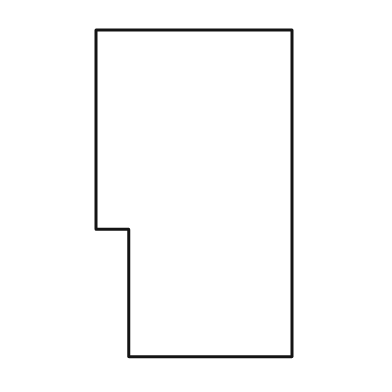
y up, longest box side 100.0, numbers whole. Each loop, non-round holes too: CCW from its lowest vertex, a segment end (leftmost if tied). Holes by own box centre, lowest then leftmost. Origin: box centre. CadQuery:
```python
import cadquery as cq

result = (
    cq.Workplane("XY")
    .moveTo(-20.0, -50.0)
    .lineTo(30.0, -50.0)
    .lineTo(30.0, 50.0)
    .lineTo(-30.0, 50.0)
    .lineTo(-30.0, -11.0)
    .lineTo(-20.0, -11.0)
    .close()
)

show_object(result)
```